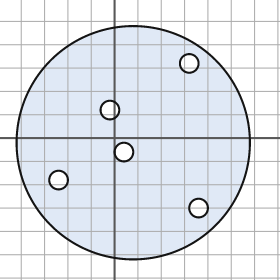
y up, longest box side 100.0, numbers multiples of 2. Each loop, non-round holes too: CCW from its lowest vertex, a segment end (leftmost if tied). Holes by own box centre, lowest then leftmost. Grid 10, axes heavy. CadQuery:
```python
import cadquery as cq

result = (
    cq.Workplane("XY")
    .moveTo(8.0, -2.0)
    .circle(50.0)
    .moveTo(36.0, -30.0)
    .circle(4.0)
    .moveTo(-24.0, -18.0)
    .circle(4.0)
    .moveTo(4.0, -6.0)
    .circle(4.0)
    .moveTo(-2.0, 12.0)
    .circle(4.0)
    .moveTo(32.0, 32.0)
    .circle(4.0)
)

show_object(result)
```